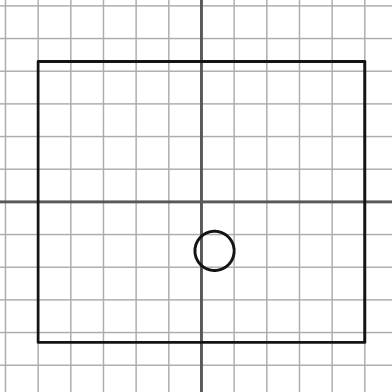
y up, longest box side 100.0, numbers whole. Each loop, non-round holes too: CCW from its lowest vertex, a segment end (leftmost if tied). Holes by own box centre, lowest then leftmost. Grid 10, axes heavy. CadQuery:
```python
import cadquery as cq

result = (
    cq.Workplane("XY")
    .moveTo(-50.0, -43.0)
    .lineTo(50.0, -43.0)
    .lineTo(50.0, 43.0)
    .lineTo(-50.0, 43.0)
    .close()
    .moveTo(4.0, -15.0)
    .circle(6.0)
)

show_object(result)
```